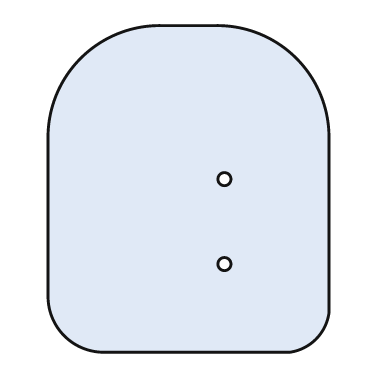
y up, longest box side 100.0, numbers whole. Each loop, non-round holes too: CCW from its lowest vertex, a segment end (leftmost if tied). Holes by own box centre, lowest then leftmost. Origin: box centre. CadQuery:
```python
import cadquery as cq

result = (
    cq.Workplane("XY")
    .moveTo(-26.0, -50.0)
    .lineTo(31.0, -50.0)
    .threePointArc((39.0, -46.0), (43.0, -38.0))
    .lineTo(43.0, 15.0)
    .threePointArc((33.0, 40.0), (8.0, 50.0))
    .lineTo(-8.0, 50.0)
    .threePointArc((-33.0, 40.0), (-43.0, 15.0))
    .lineTo(-43.0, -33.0)
    .threePointArc((-38.0, -45.0), (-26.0, -50.0))
    .close()
    .moveTo(11.0, -23.0)
    .circle(2.0)
    .moveTo(11.0, 3.0)
    .circle(2.0)
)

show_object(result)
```